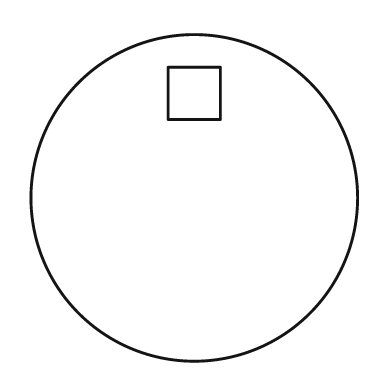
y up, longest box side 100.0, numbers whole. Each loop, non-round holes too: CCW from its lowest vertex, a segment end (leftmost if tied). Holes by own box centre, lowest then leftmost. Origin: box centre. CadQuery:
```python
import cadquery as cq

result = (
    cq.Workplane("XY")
    .moveTo(0.0, 0.0)
    .circle(50.0)
    .moveTo(-8.0, 24.0)
    .lineTo(8.0, 24.0)
    .lineTo(8.0, 40.0)
    .lineTo(-8.0, 40.0)
    .close()
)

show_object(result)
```